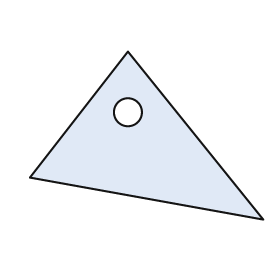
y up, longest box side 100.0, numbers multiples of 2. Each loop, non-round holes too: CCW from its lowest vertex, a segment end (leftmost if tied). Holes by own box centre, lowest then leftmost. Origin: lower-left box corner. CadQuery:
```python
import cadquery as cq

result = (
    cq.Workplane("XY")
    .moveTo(100.0, 0.0)
    .lineTo(42.0, 72.0)
    .lineTo(0.0, 18.0)
    .close()
    .moveTo(42.0, 46.0)
    .circle(6.0)
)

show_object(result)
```